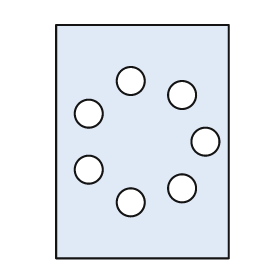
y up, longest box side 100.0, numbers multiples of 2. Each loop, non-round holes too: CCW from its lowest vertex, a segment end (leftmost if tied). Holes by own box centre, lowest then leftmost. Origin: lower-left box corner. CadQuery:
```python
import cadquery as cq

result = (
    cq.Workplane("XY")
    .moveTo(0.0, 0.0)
    .lineTo(74.0, 0.0)
    .lineTo(74.0, 100.0)
    .lineTo(0.0, 100.0)
    .close()
    .moveTo(32.0, 24.0)
    .circle(6.0)
    .moveTo(54.0, 30.0)
    .circle(6.0)
    .moveTo(14.0, 38.0)
    .circle(6.0)
    .moveTo(64.0, 50.0)
    .circle(6.0)
    .moveTo(14.0, 62.0)
    .circle(6.0)
    .moveTo(54.0, 70.0)
    .circle(6.0)
    .moveTo(32.0, 76.0)
    .circle(6.0)
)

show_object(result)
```